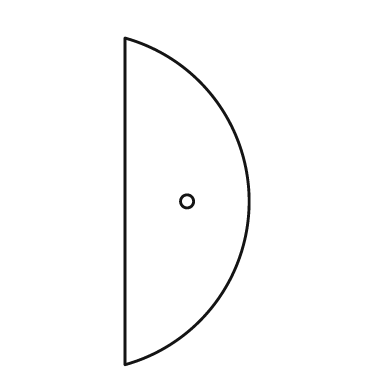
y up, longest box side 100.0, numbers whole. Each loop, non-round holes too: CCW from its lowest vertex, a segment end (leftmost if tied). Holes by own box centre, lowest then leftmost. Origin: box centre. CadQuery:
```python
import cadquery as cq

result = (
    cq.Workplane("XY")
    .moveTo(-19.0, -50.0)
    .threePointArc((19.0, 0.0), (-19.0, 50.0))
    .close()
    .moveTo(0.0, 0.0)
    .circle(2.0)
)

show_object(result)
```